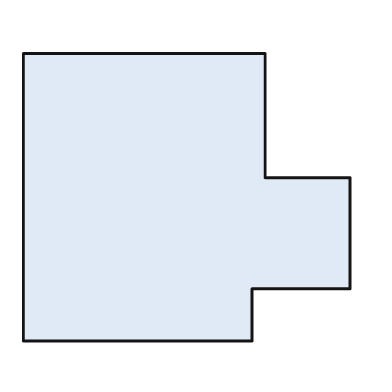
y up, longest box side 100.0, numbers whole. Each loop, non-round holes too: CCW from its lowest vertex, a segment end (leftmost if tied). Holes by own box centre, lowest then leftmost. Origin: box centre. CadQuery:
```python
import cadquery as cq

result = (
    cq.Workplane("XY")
    .moveTo(-50.0, -44.0)
    .lineTo(20.0, -44.0)
    .lineTo(20.0, -28.0)
    .lineTo(50.0, -28.0)
    .lineTo(50.0, 6.0)
    .lineTo(24.0, 6.0)
    .lineTo(24.0, 44.0)
    .lineTo(-50.0, 44.0)
    .close()
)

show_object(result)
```